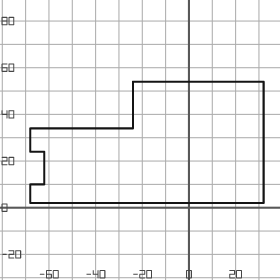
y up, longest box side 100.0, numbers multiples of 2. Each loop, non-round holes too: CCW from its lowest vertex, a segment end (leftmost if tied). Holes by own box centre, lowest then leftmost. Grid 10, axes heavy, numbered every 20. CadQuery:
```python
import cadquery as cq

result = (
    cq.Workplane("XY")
    .moveTo(-68.0, 2.0)
    .lineTo(32.0, 2.0)
    .lineTo(32.0, 54.0)
    .lineTo(-24.0, 54.0)
    .lineTo(-24.0, 34.0)
    .lineTo(-68.0, 34.0)
    .lineTo(-68.0, 24.0)
    .lineTo(-62.0, 24.0)
    .lineTo(-62.0, 10.0)
    .lineTo(-68.0, 10.0)
    .close()
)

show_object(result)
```